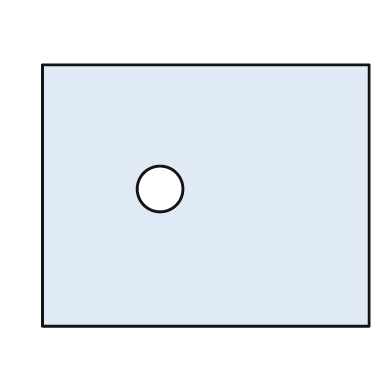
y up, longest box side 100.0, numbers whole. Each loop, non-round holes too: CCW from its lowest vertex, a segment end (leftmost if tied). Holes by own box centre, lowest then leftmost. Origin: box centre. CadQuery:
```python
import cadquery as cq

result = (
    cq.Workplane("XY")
    .moveTo(-50.0, -40.0)
    .lineTo(50.0, -40.0)
    .lineTo(50.0, 40.0)
    .lineTo(-50.0, 40.0)
    .close()
    .moveTo(-14.0, 2.0)
    .circle(7.0)
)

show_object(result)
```